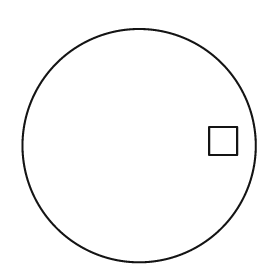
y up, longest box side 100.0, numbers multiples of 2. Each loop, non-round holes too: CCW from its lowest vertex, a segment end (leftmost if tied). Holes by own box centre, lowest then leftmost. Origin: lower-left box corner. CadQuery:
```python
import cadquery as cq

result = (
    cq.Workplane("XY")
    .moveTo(50.0, 50.0)
    .circle(50.0)
    .moveTo(80.0, 46.0)
    .lineTo(92.0, 46.0)
    .lineTo(92.0, 58.0)
    .lineTo(80.0, 58.0)
    .close()
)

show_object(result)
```